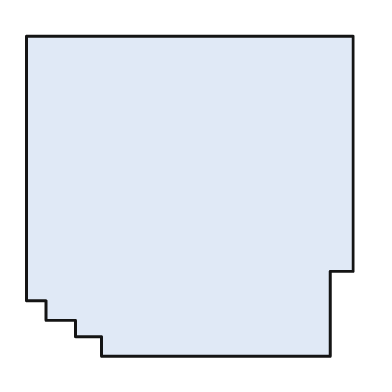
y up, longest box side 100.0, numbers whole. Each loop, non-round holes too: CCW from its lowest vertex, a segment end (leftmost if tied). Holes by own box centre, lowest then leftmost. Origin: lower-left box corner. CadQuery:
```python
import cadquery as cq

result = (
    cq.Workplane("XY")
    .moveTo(23.0, 0.0)
    .lineTo(93.0, 0.0)
    .lineTo(93.0, 26.0)
    .lineTo(100.0, 26.0)
    .lineTo(100.0, 98.0)
    .lineTo(0.0, 98.0)
    .lineTo(0.0, 17.0)
    .lineTo(6.0, 17.0)
    .lineTo(6.0, 11.0)
    .lineTo(15.0, 11.0)
    .lineTo(15.0, 6.0)
    .lineTo(23.0, 6.0)
    .close()
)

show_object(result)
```